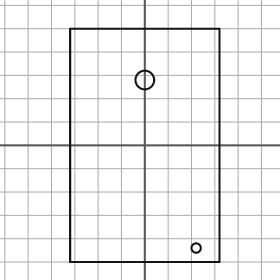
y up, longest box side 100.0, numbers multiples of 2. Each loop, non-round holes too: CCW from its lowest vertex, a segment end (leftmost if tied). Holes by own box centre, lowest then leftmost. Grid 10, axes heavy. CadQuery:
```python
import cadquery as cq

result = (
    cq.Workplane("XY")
    .moveTo(-32.0, -50.0)
    .lineTo(32.0, -50.0)
    .lineTo(32.0, 50.0)
    .lineTo(-32.0, 50.0)
    .close()
    .moveTo(22.0, -44.0)
    .circle(2.0)
    .moveTo(0.0, 28.0)
    .circle(4.0)
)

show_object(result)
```